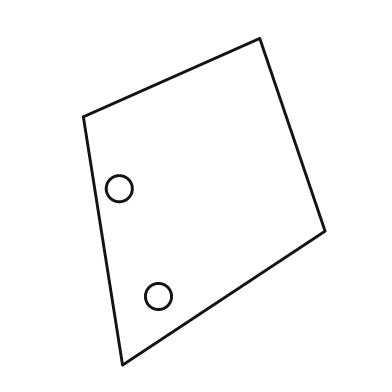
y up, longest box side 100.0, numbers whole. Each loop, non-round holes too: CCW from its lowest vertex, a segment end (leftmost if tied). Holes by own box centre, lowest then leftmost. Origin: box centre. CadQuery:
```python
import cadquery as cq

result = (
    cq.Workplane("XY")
    .moveTo(-25.0, -50.0)
    .lineTo(37.0, -9.0)
    .lineTo(17.0, 50.0)
    .lineTo(-37.0, 26.0)
    .close()
    .moveTo(-14.0, -29.0)
    .circle(4.0)
    .moveTo(-26.0, 4.0)
    .circle(4.0)
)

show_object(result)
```